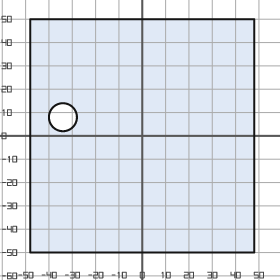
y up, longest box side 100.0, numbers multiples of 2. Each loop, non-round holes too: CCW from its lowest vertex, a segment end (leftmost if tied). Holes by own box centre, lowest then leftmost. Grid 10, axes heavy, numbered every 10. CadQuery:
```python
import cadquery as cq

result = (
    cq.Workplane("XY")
    .moveTo(-48.0, -50.0)
    .lineTo(48.0, -50.0)
    .lineTo(48.0, 50.0)
    .lineTo(-48.0, 50.0)
    .close()
    .moveTo(-34.0, 8.0)
    .circle(6.0)
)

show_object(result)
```